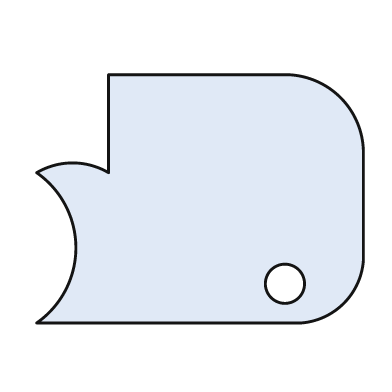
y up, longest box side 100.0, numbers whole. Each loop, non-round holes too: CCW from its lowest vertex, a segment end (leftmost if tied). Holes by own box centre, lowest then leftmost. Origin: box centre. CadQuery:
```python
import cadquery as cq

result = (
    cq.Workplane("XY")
    .moveTo(-50.0, -38.0)
    .lineTo(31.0, -38.0)
    .threePointArc((44.0, -32.0), (50.0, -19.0))
    .lineTo(50.0, 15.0)
    .threePointArc((43.0, 31.0), (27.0, 38.0))
    .lineTo(-28.0, 38.0)
    .lineTo(-28.0, 8.0)
    .threePointArc((-39.0, 11.0), (-50.0, 8.0))
    .threePointArc((-38.0, -15.0), (-50.0, -38.0))
    .close()
    .moveTo(26.0, -26.0)
    .circle(6.0)
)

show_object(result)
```